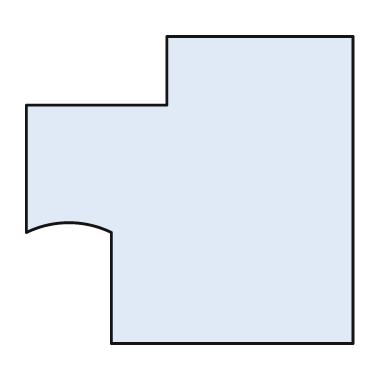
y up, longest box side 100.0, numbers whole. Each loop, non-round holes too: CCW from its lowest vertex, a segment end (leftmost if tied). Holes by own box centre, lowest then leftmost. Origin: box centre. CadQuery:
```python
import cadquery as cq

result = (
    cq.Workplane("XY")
    .moveTo(-24.0, -47.0)
    .lineTo(50.0, -47.0)
    .lineTo(50.0, 47.0)
    .lineTo(-7.0, 47.0)
    .lineTo(-7.0, 26.0)
    .lineTo(-50.0, 26.0)
    .lineTo(-50.0, -13.0)
    .threePointArc((-37.0, -10.0), (-24.0, -13.0))
    .close()
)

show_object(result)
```